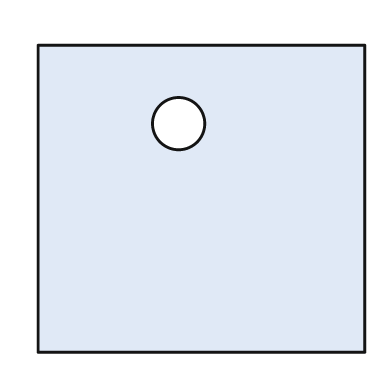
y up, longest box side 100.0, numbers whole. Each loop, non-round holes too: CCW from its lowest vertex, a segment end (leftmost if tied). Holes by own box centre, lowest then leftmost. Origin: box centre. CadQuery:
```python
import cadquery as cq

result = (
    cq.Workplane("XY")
    .moveTo(-50.0, -47.0)
    .lineTo(50.0, -47.0)
    .lineTo(50.0, 47.0)
    .lineTo(-50.0, 47.0)
    .close()
    .moveTo(-7.0, 23.0)
    .circle(8.0)
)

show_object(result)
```